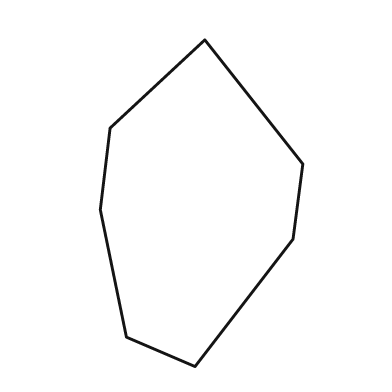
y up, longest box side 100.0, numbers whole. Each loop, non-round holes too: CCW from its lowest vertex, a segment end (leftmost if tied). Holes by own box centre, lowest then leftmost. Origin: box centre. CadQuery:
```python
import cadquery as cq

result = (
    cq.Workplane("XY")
    .moveTo(-2.0, -50.0)
    .lineTo(28.0, -11.0)
    .lineTo(31.0, 12.0)
    .lineTo(1.0, 50.0)
    .lineTo(-28.0, 23.0)
    .lineTo(-31.0, -2.0)
    .lineTo(-23.0, -41.0)
    .close()
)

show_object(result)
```